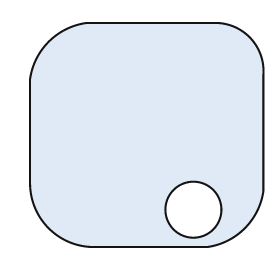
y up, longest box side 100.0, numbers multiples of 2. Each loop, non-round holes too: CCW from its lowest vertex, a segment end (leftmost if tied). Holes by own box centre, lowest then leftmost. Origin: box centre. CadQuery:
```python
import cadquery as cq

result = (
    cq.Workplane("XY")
    .moveTo(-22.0, -48.0)
    .lineTo(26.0, -48.0)
    .threePointArc((42.0, -40.0), (50.0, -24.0))
    .lineTo(50.0, 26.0)
    .threePointArc((44.0, 42.0), (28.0, 48.0))
    .lineTo(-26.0, 48.0)
    .threePointArc((-42.0, 40.0), (-50.0, 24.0))
    .lineTo(-50.0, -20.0)
    .threePointArc((-42.0, -40.0), (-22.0, -48.0))
    .close()
    .moveTo(20.0, -32.0)
    .circle(12.0)
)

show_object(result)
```